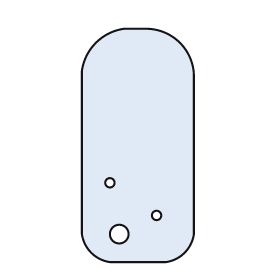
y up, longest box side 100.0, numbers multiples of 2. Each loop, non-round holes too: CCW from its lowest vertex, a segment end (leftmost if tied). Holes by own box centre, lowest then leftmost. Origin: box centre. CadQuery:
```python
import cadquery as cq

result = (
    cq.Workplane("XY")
    .moveTo(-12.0, -50.0)
    .lineTo(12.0, -50.0)
    .threePointArc((20.0, -46.0), (24.0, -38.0))
    .lineTo(24.0, 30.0)
    .threePointArc((18.0, 44.0), (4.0, 50.0))
    .lineTo(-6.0, 50.0)
    .threePointArc((-18.0, 44.0), (-24.0, 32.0))
    .lineTo(-24.0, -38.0)
    .threePointArc((-20.0, -46.0), (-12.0, -50.0))
    .close()
    .moveTo(-8.0, -38.0)
    .circle(4.0)
    .moveTo(8.0, -30.0)
    .circle(2.0)
    .moveTo(-12.0, -16.0)
    .circle(2.0)
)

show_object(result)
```